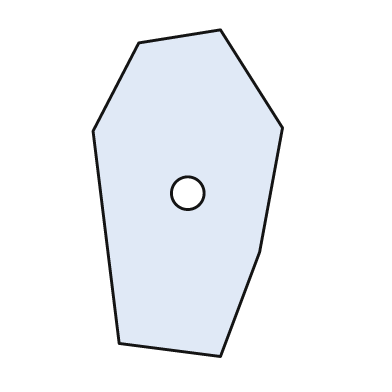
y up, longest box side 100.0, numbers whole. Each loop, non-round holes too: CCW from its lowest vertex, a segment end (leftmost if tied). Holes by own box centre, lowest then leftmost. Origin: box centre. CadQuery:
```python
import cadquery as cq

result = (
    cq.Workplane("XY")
    .moveTo(10.0, -50.0)
    .lineTo(22.0, -18.0)
    .lineTo(29.0, 20.0)
    .lineTo(10.0, 50.0)
    .lineTo(-15.0, 46.0)
    .lineTo(-29.0, 19.0)
    .lineTo(-21.0, -46.0)
    .close()
    .moveTo(0.0, 0.0)
    .circle(5.0)
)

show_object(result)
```